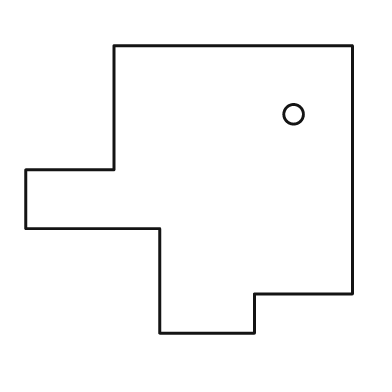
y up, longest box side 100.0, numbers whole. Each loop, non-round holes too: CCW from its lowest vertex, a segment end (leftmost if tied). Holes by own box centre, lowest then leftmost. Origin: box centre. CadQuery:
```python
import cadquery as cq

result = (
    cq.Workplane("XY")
    .moveTo(-9.0, -44.0)
    .lineTo(20.0, -44.0)
    .lineTo(20.0, -32.0)
    .lineTo(50.0, -32.0)
    .lineTo(50.0, 44.0)
    .lineTo(-23.0, 44.0)
    .lineTo(-23.0, 6.0)
    .lineTo(-50.0, 6.0)
    .lineTo(-50.0, -12.0)
    .lineTo(-9.0, -12.0)
    .close()
    .moveTo(32.0, 23.0)
    .circle(3.0)
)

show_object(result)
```